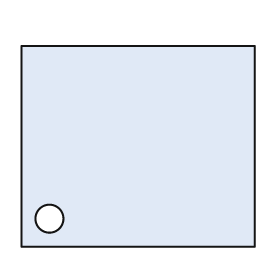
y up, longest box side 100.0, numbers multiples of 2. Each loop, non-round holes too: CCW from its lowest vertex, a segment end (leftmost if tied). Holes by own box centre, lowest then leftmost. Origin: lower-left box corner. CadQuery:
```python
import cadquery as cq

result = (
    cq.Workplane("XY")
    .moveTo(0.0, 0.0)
    .lineTo(100.0, 0.0)
    .lineTo(100.0, 86.0)
    .lineTo(0.0, 86.0)
    .close()
    .moveTo(12.0, 12.0)
    .circle(6.0)
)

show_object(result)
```